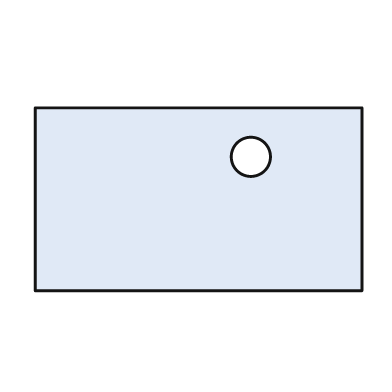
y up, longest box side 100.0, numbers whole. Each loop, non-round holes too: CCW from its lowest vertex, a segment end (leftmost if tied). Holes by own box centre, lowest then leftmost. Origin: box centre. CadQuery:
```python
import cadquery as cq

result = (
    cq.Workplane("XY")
    .moveTo(-50.0, -28.0)
    .lineTo(50.0, -28.0)
    .lineTo(50.0, 28.0)
    .lineTo(-50.0, 28.0)
    .close()
    .moveTo(16.0, 13.0)
    .circle(6.0)
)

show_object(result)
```